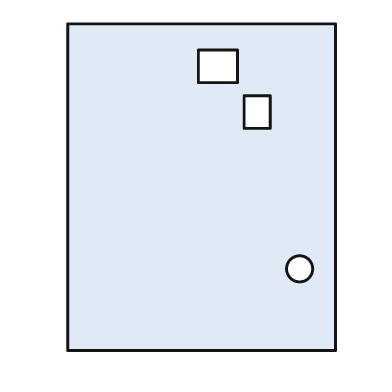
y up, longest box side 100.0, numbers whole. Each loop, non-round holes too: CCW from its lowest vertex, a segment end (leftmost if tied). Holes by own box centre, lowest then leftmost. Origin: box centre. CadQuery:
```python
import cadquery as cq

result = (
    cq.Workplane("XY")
    .moveTo(-41.0, -50.0)
    .lineTo(41.0, -50.0)
    .lineTo(41.0, 50.0)
    .lineTo(-41.0, 50.0)
    .close()
    .moveTo(30.0, -25.0)
    .circle(4.0)
    .moveTo(13.0, 18.0)
    .lineTo(21.0, 18.0)
    .lineTo(21.0, 28.0)
    .lineTo(13.0, 28.0)
    .close()
    .moveTo(-1.0, 32.0)
    .lineTo(11.0, 32.0)
    .lineTo(11.0, 42.0)
    .lineTo(-1.0, 42.0)
    .close()
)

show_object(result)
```